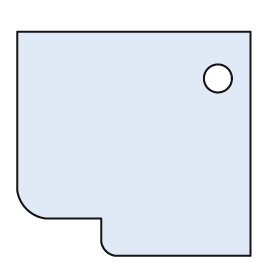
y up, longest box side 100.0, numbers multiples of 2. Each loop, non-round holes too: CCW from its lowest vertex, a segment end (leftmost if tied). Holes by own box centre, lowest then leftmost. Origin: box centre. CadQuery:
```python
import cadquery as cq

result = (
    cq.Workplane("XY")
    .moveTo(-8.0, -48.0)
    .lineTo(50.0, -48.0)
    .lineTo(50.0, 48.0)
    .lineTo(-50.0, 48.0)
    .lineTo(-50.0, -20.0)
    .threePointArc((-46.0, -28.0), (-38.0, -32.0))
    .lineTo(-14.0, -32.0)
    .lineTo(-14.0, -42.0)
    .threePointArc((-12.0, -46.0), (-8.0, -48.0))
    .close()
    .moveTo(36.0, 28.0)
    .circle(6.0)
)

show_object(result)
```